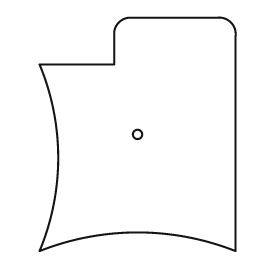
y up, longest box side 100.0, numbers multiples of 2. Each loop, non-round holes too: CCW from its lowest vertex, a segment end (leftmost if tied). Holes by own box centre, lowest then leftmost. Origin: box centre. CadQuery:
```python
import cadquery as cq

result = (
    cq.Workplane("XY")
    .moveTo(-42.0, -50.0)
    .threePointArc((0.0, -42.0), (42.0, -50.0))
    .lineTo(42.0, 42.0)
    .threePointArc((40.0, 48.0), (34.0, 50.0))
    .lineTo(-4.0, 50.0)
    .threePointArc((-8.0, 48.0), (-10.0, 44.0))
    .lineTo(-10.0, 30.0)
    .lineTo(-42.0, 30.0)
    .threePointArc((-34.0, -10.0), (-42.0, -50.0))
    .close()
    .moveTo(0.0, 0.0)
    .circle(2.0)
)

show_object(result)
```